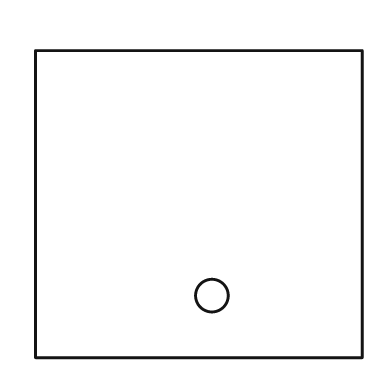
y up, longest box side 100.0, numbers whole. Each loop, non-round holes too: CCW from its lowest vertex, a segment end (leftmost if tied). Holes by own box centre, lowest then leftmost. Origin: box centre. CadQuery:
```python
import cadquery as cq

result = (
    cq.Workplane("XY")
    .moveTo(-50.0, -47.0)
    .lineTo(50.0, -47.0)
    .lineTo(50.0, 47.0)
    .lineTo(-50.0, 47.0)
    .close()
    .moveTo(4.0, -28.0)
    .circle(5.0)
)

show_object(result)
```